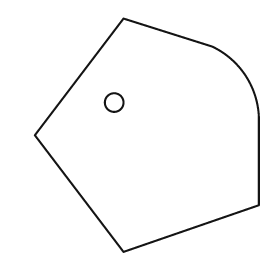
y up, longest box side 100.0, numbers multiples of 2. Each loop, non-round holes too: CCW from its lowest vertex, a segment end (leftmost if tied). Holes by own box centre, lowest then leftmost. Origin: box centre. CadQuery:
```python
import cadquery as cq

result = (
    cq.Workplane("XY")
    .moveTo(-10.0, -50.0)
    .lineTo(48.0, -30.0)
    .lineTo(48.0, 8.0)
    .threePointArc((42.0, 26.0), (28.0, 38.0))
    .lineTo(-10.0, 50.0)
    .lineTo(-48.0, 0.0)
    .close()
    .moveTo(-14.0, 14.0)
    .circle(4.0)
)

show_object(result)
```